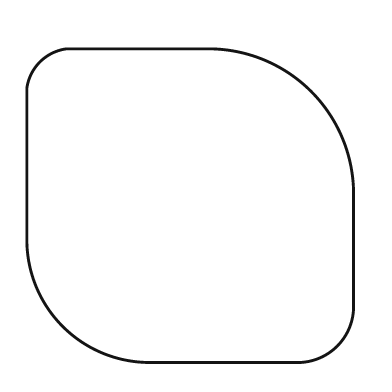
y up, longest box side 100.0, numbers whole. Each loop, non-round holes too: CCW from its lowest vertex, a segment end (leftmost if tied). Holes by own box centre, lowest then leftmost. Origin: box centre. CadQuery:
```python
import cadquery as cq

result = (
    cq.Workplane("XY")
    .moveTo(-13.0, -48.0)
    .lineTo(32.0, -48.0)
    .threePointArc((45.0, -43.0), (50.0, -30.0))
    .lineTo(50.0, 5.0)
    .threePointArc((37.0, 35.0), (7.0, 48.0))
    .lineTo(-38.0, 48.0)
    .threePointArc((-46.0, 44.0), (-50.0, 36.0))
    .lineTo(-50.0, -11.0)
    .threePointArc((-39.0, -37.0), (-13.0, -48.0))
    .close()
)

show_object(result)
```